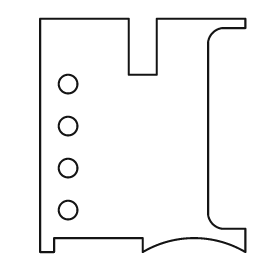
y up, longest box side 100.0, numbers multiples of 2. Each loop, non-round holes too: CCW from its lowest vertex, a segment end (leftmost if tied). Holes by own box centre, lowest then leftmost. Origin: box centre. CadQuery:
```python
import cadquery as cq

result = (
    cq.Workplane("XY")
    .moveTo(-44.0, -50.0)
    .lineTo(-38.0, -50.0)
    .lineTo(-38.0, -44.0)
    .lineTo(0.0, -44.0)
    .lineTo(0.0, -50.0)
    .threePointArc((22.0, -44.0), (44.0, -50.0))
    .lineTo(44.0, -40.0)
    .lineTo(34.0, -40.0)
    .threePointArc((30.0, -38.0), (28.0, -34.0))
    .lineTo(28.0, 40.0)
    .threePointArc((30.0, 44.0), (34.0, 46.0))
    .lineTo(44.0, 46.0)
    .lineTo(44.0, 50.0)
    .lineTo(6.0, 50.0)
    .lineTo(6.0, 26.0)
    .lineTo(-6.0, 26.0)
    .lineTo(-6.0, 50.0)
    .lineTo(-44.0, 50.0)
    .close()
    .moveTo(-32.0, -32.0)
    .circle(4.0)
    .moveTo(-32.0, -14.0)
    .circle(4.0)
    .moveTo(-32.0, 4.0)
    .circle(4.0)
    .moveTo(-32.0, 22.0)
    .circle(4.0)
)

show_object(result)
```